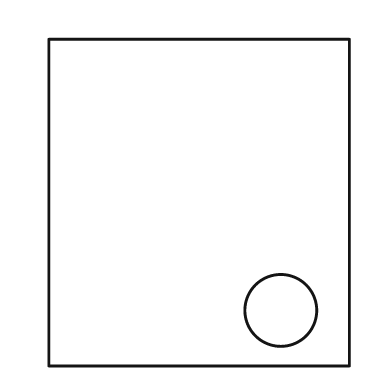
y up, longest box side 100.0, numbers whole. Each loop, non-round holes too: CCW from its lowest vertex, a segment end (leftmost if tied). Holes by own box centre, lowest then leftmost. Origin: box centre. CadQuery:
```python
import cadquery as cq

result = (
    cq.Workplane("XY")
    .moveTo(-46.0, -50.0)
    .lineTo(46.0, -50.0)
    .lineTo(46.0, 50.0)
    .lineTo(-46.0, 50.0)
    .close()
    .moveTo(25.0, -33.0)
    .circle(11.0)
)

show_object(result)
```